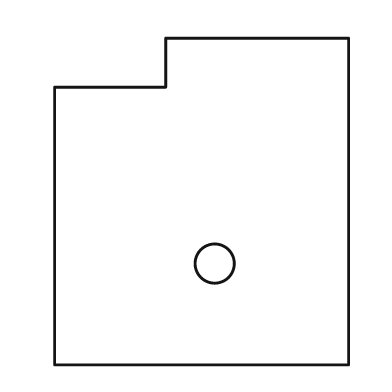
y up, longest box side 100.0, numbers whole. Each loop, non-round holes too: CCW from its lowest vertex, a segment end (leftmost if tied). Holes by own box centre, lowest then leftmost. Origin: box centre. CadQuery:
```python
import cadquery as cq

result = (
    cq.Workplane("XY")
    .moveTo(-45.0, -50.0)
    .lineTo(45.0, -50.0)
    .lineTo(45.0, 50.0)
    .lineTo(-11.0, 50.0)
    .lineTo(-11.0, 35.0)
    .lineTo(-45.0, 35.0)
    .close()
    .moveTo(4.0, -19.0)
    .circle(6.0)
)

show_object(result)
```